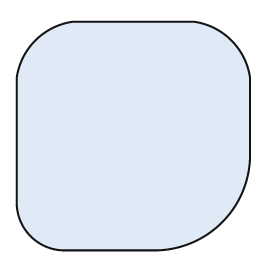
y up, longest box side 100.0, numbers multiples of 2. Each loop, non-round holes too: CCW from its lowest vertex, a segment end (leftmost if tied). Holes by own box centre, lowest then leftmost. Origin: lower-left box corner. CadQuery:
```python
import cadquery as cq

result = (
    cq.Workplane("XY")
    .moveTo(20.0, 0.0)
    .lineTo(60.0, 0.0)
    .threePointArc((88.0, 12.0), (100.0, 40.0))
    .lineTo(100.0, 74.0)
    .threePointArc((92.0, 90.0), (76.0, 98.0))
    .lineTo(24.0, 98.0)
    .threePointArc((8.0, 90.0), (0.0, 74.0))
    .lineTo(0.0, 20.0)
    .threePointArc((6.0, 6.0), (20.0, 0.0))
    .close()
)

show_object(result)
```